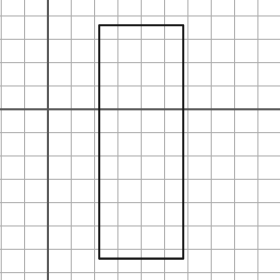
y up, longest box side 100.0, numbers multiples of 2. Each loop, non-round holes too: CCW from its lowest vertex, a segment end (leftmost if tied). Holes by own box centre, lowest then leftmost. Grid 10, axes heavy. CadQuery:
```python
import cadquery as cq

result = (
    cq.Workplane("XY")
    .moveTo(22.0, -64.0)
    .lineTo(58.0, -64.0)
    .lineTo(58.0, 36.0)
    .lineTo(22.0, 36.0)
    .close()
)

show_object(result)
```